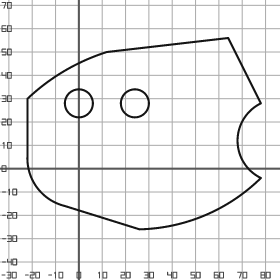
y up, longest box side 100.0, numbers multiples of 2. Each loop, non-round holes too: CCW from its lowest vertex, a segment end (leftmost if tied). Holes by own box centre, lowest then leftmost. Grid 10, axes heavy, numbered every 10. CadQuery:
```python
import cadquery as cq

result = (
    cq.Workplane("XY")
    .moveTo(26.0, -26.0)
    .threePointArc((54.0, -20.0), (78.0, -4.0))
    .threePointArc((68.0, 12.0), (78.0, 28.0))
    .lineTo(64.0, 56.0)
    .lineTo(12.0, 50.0)
    .threePointArc((-6.0, 42.0), (-22.0, 30.0))
    .lineTo(-22.0, 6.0)
    .threePointArc((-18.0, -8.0), (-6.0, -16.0))
    .close()
    .moveTo(0.0, 28.0)
    .circle(6.0)
    .moveTo(24.0, 28.0)
    .circle(6.0)
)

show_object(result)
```